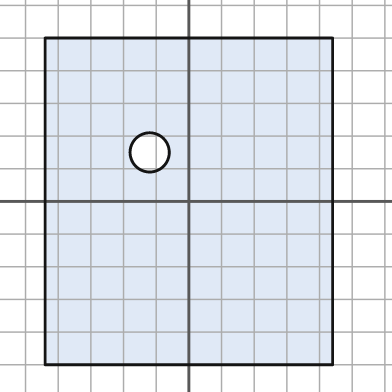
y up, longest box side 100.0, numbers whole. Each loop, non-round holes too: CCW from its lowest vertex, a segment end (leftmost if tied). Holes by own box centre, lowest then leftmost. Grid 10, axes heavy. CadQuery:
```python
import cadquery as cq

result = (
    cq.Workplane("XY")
    .moveTo(-44.0, -50.0)
    .lineTo(44.0, -50.0)
    .lineTo(44.0, 50.0)
    .lineTo(-44.0, 50.0)
    .close()
    .moveTo(-12.0, 15.0)
    .circle(6.0)
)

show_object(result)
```